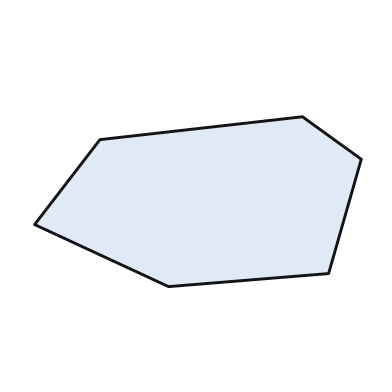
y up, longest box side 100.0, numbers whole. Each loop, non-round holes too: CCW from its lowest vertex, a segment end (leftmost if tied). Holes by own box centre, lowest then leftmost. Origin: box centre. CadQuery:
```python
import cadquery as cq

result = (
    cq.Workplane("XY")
    .moveTo(-9.0, -26.0)
    .lineTo(40.0, -22.0)
    .lineTo(50.0, 13.0)
    .lineTo(32.0, 26.0)
    .lineTo(-30.0, 19.0)
    .lineTo(-50.0, -7.0)
    .close()
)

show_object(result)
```